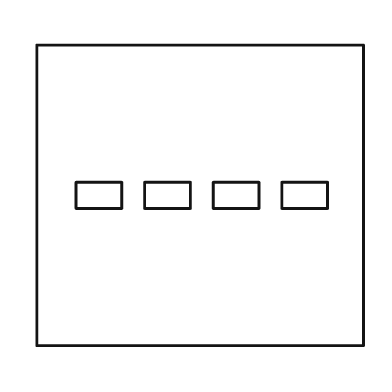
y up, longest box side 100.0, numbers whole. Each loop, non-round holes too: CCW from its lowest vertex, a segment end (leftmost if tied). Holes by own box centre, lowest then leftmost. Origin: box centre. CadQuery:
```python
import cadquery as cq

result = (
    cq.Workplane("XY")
    .moveTo(-50.0, -46.0)
    .lineTo(50.0, -46.0)
    .lineTo(50.0, 46.0)
    .lineTo(-50.0, 46.0)
    .close()
    .moveTo(-38.0, -4.0)
    .lineTo(-24.0, -4.0)
    .lineTo(-24.0, 4.0)
    .lineTo(-38.0, 4.0)
    .close()
    .moveTo(-17.0, -4.0)
    .lineTo(-3.0, -4.0)
    .lineTo(-3.0, 4.0)
    .lineTo(-17.0, 4.0)
    .close()
    .moveTo(4.0, -4.0)
    .lineTo(18.0, -4.0)
    .lineTo(18.0, 4.0)
    .lineTo(4.0, 4.0)
    .close()
    .moveTo(25.0, -4.0)
    .lineTo(39.0, -4.0)
    .lineTo(39.0, 4.0)
    .lineTo(25.0, 4.0)
    .close()
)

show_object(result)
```